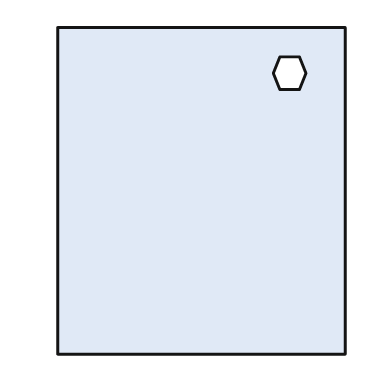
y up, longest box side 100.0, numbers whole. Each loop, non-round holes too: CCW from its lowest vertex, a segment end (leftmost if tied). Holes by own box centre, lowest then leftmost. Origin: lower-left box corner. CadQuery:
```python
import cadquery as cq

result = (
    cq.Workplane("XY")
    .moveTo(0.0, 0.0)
    .lineTo(88.0, 0.0)
    .lineTo(88.0, 100.0)
    .lineTo(0.0, 100.0)
    .close()
    .moveTo(68.0, 81.0)
    .lineTo(74.0, 81.0)
    .lineTo(76.0, 86.0)
    .lineTo(74.0, 91.0)
    .lineTo(68.0, 91.0)
    .lineTo(66.0, 86.0)
    .close()
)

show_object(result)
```